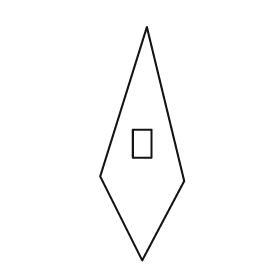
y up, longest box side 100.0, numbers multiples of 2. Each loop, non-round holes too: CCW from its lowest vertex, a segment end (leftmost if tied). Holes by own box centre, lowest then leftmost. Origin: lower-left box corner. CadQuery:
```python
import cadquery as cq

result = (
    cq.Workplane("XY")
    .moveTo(18.0, 0.0)
    .lineTo(36.0, 34.0)
    .lineTo(20.0, 100.0)
    .lineTo(0.0, 36.0)
    .close()
    .moveTo(14.0, 44.0)
    .lineTo(22.0, 44.0)
    .lineTo(22.0, 56.0)
    .lineTo(14.0, 56.0)
    .close()
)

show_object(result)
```